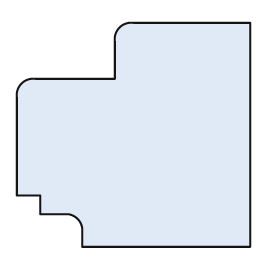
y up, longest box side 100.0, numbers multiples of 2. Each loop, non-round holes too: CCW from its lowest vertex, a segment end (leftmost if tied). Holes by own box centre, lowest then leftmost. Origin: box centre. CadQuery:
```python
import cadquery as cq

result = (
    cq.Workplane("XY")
    .moveTo(-22.0, -48.0)
    .lineTo(50.0, -48.0)
    .lineTo(50.0, 48.0)
    .lineTo(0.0, 48.0)
    .threePointArc((-6.0, 46.0), (-8.0, 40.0))
    .lineTo(-8.0, 24.0)
    .lineTo(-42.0, 24.0)
    .threePointArc((-48.0, 22.0), (-50.0, 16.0))
    .lineTo(-50.0, -26.0)
    .lineTo(-40.0, -26.0)
    .lineTo(-40.0, -34.0)
    .lineTo(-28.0, -34.0)
    .threePointArc((-24.0, -36.0), (-22.0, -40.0))
    .close()
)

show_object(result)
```